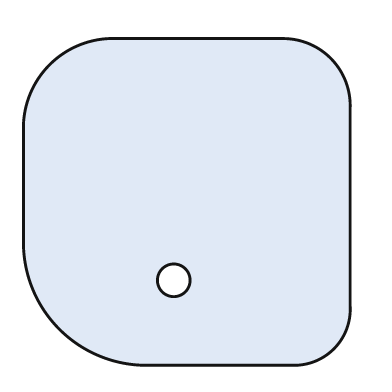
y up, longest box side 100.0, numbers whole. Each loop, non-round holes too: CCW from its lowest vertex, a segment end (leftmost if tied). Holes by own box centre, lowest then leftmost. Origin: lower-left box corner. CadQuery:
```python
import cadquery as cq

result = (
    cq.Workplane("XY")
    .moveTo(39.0, 0.0)
    .lineTo(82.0, 0.0)
    .threePointArc((95.0, 5.0), (100.0, 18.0))
    .lineTo(100.0, 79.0)
    .threePointArc((94.0, 94.0), (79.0, 100.0))
    .lineTo(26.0, 100.0)
    .threePointArc((8.0, 92.0), (0.0, 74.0))
    .lineTo(0.0, 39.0)
    .threePointArc((11.0, 11.0), (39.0, 0.0))
    .close()
    .moveTo(46.0, 26.0)
    .circle(5.0)
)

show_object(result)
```